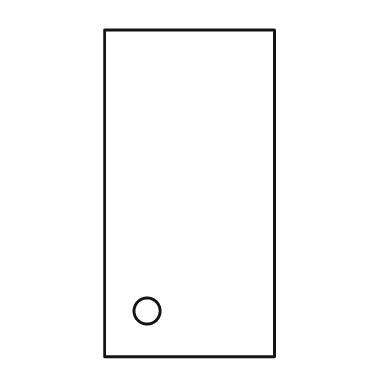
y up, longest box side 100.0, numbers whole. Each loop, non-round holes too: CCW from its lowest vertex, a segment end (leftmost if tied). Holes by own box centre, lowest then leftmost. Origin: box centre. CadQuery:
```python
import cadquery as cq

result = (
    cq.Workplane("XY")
    .moveTo(-26.0, -50.0)
    .lineTo(26.0, -50.0)
    .lineTo(26.0, 50.0)
    .lineTo(-26.0, 50.0)
    .close()
    .moveTo(-13.0, -36.0)
    .circle(4.0)
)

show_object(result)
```